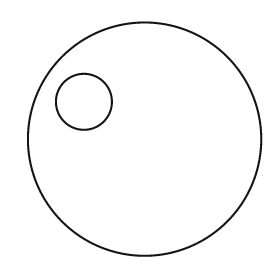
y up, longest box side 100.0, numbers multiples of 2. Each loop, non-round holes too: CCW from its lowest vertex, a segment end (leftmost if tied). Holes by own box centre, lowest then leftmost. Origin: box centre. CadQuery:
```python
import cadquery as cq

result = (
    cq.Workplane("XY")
    .moveTo(0.0, 0.0)
    .circle(50.0)
    .moveTo(-26.0, 16.0)
    .circle(12.0)
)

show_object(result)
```